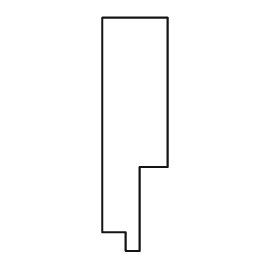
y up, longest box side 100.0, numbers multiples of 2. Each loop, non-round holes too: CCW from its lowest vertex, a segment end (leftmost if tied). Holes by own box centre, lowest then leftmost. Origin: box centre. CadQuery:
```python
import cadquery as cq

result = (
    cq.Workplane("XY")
    .moveTo(-4.0, -50.0)
    .lineTo(2.0, -50.0)
    .lineTo(2.0, -14.0)
    .lineTo(14.0, -14.0)
    .lineTo(14.0, 50.0)
    .lineTo(-14.0, 50.0)
    .lineTo(-14.0, -42.0)
    .lineTo(-4.0, -42.0)
    .close()
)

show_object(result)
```